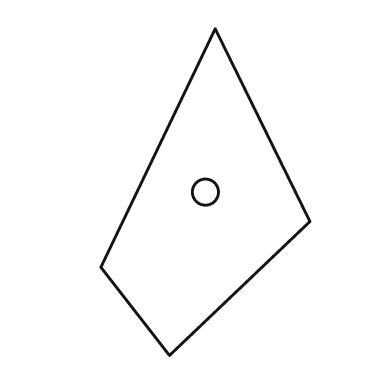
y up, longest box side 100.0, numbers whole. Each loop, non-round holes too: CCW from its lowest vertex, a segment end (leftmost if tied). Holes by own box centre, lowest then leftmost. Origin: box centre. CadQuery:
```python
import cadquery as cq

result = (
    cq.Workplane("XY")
    .moveTo(-11.0, -50.0)
    .lineTo(32.0, -9.0)
    .lineTo(3.0, 50.0)
    .lineTo(-32.0, -23.0)
    .close()
    .moveTo(0.0, 0.0)
    .circle(4.0)
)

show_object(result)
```